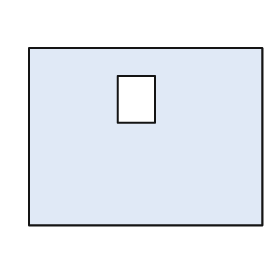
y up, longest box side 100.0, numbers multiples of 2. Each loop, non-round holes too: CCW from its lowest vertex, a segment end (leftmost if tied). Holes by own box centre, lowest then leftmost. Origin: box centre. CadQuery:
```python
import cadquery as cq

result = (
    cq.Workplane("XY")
    .moveTo(-50.0, -38.0)
    .lineTo(50.0, -38.0)
    .lineTo(50.0, 38.0)
    .lineTo(-50.0, 38.0)
    .close()
    .moveTo(-12.0, 6.0)
    .lineTo(4.0, 6.0)
    .lineTo(4.0, 26.0)
    .lineTo(-12.0, 26.0)
    .close()
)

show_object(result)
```